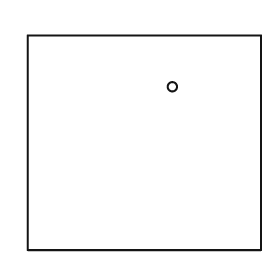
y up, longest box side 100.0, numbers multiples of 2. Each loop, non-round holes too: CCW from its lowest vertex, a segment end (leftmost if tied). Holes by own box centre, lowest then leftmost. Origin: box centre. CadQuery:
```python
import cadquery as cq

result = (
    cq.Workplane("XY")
    .moveTo(-50.0, -46.0)
    .lineTo(50.0, -46.0)
    .lineTo(50.0, 46.0)
    .lineTo(-50.0, 46.0)
    .close()
    .moveTo(12.0, 24.0)
    .circle(2.0)
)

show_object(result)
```